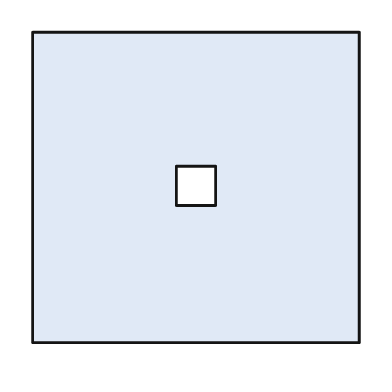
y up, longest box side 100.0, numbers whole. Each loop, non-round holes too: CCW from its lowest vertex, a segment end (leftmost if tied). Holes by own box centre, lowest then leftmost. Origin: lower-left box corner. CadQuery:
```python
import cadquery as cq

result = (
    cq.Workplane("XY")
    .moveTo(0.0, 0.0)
    .lineTo(100.0, 0.0)
    .lineTo(100.0, 95.0)
    .lineTo(0.0, 95.0)
    .close()
    .moveTo(44.0, 42.0)
    .lineTo(56.0, 42.0)
    .lineTo(56.0, 54.0)
    .lineTo(44.0, 54.0)
    .close()
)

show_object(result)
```